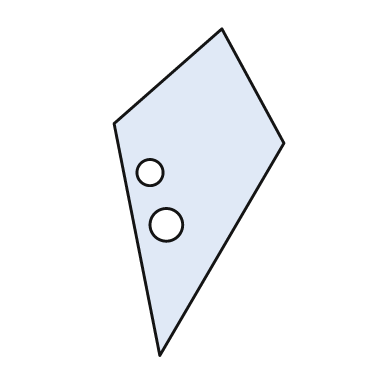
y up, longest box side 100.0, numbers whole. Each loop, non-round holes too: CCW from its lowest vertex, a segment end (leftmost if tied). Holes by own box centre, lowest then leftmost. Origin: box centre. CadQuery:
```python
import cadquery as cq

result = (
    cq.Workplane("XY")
    .moveTo(-12.0, -50.0)
    .lineTo(26.0, 15.0)
    .lineTo(7.0, 50.0)
    .lineTo(-26.0, 21.0)
    .close()
    .moveTo(-10.0, -10.0)
    .circle(5.0)
    .moveTo(-15.0, 6.0)
    .circle(4.0)
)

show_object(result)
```